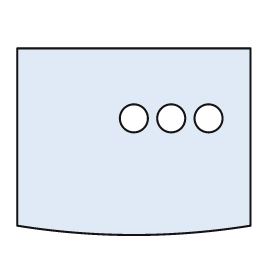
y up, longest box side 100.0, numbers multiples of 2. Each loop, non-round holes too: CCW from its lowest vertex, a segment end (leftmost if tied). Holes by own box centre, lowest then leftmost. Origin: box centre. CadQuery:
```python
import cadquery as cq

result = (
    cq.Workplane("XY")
    .moveTo(-50.0, -36.0)
    .threePointArc((0.0, -40.0), (50.0, -36.0))
    .lineTo(50.0, 40.0)
    .lineTo(-50.0, 40.0)
    .close()
    .moveTo(0.0, 10.0)
    .circle(6.0)
    .moveTo(16.0, 10.0)
    .circle(6.0)
    .moveTo(32.0, 10.0)
    .circle(6.0)
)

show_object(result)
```